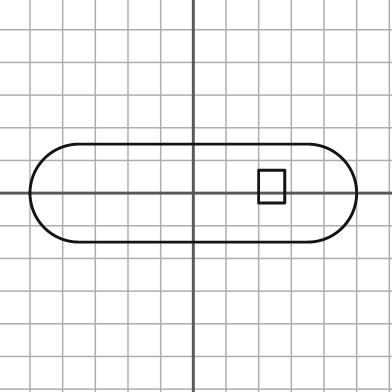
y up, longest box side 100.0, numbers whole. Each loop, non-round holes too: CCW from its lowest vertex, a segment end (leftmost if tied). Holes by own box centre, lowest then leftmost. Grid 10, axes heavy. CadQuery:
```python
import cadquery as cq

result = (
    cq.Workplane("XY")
    .moveTo(-35.0, -15.0)
    .lineTo(35.0, -15.0)
    .threePointArc((50.0, 0.0), (35.0, 15.0))
    .lineTo(-35.0, 15.0)
    .threePointArc((-50.0, 0.0), (-35.0, -15.0))
    .close()
    .moveTo(20.0, -3.0)
    .lineTo(28.0, -3.0)
    .lineTo(28.0, 7.0)
    .lineTo(20.0, 7.0)
    .close()
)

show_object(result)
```